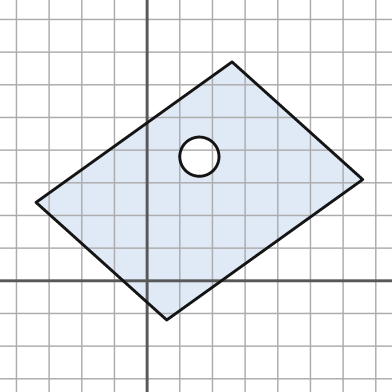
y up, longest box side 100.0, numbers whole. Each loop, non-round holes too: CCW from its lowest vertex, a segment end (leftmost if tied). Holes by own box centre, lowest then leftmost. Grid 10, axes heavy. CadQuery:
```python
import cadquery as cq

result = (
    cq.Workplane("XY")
    .moveTo(6.0, -12.0)
    .lineTo(66.0, 31.0)
    .lineTo(26.0, 67.0)
    .lineTo(-34.0, 24.0)
    .close()
    .moveTo(16.0, 38.0)
    .circle(6.0)
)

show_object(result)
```